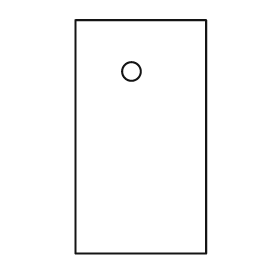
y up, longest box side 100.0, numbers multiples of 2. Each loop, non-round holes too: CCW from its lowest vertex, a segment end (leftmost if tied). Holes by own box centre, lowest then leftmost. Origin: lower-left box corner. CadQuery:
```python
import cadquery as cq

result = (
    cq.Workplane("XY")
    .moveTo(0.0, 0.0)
    .lineTo(56.0, 0.0)
    .lineTo(56.0, 100.0)
    .lineTo(0.0, 100.0)
    .close()
    .moveTo(24.0, 78.0)
    .circle(4.0)
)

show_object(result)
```